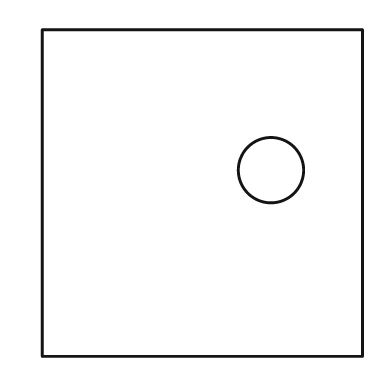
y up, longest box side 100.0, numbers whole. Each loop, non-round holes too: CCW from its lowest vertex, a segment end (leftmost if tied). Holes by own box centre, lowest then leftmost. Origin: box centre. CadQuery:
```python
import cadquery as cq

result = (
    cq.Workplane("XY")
    .moveTo(-49.0, -50.0)
    .lineTo(49.0, -50.0)
    .lineTo(49.0, 50.0)
    .lineTo(-49.0, 50.0)
    .close()
    .moveTo(21.0, 7.0)
    .circle(10.0)
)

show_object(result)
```